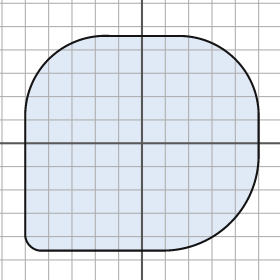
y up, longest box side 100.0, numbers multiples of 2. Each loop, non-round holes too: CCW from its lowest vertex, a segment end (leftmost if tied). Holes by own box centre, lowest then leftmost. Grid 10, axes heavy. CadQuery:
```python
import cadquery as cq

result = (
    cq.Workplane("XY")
    .moveTo(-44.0, -46.0)
    .lineTo(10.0, -46.0)
    .threePointArc((38.0, -34.0), (50.0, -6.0))
    .lineTo(50.0, 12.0)
    .threePointArc((40.0, 36.0), (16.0, 46.0))
    .lineTo(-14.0, 46.0)
    .threePointArc((-40.0, 36.0), (-50.0, 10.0))
    .lineTo(-50.0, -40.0)
    .threePointArc((-48.0, -44.0), (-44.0, -46.0))
    .close()
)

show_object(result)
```